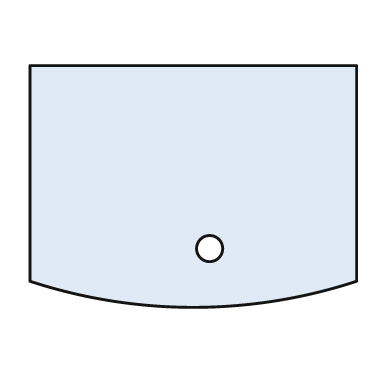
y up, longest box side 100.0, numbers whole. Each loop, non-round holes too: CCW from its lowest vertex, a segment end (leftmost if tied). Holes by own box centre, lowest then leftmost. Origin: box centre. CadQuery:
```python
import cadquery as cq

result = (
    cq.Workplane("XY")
    .moveTo(-50.0, -29.0)
    .threePointArc((0.0, -37.0), (50.0, -29.0))
    .lineTo(50.0, 37.0)
    .lineTo(-50.0, 37.0)
    .close()
    .moveTo(5.0, -19.0)
    .circle(4.0)
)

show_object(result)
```